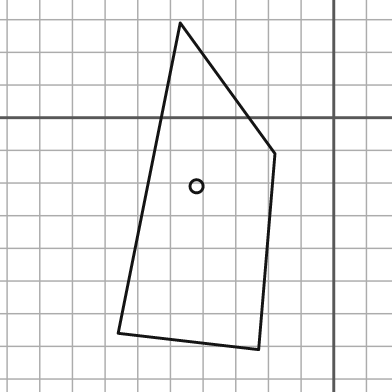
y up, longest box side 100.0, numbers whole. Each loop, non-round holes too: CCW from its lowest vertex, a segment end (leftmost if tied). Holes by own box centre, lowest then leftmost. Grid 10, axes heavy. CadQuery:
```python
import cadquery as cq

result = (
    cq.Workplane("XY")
    .moveTo(-23.0, -71.0)
    .lineTo(-18.0, -11.0)
    .lineTo(-47.0, 29.0)
    .lineTo(-66.0, -66.0)
    .close()
    .moveTo(-42.0, -21.0)
    .circle(2.0)
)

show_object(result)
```